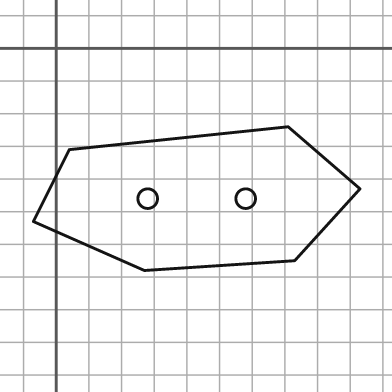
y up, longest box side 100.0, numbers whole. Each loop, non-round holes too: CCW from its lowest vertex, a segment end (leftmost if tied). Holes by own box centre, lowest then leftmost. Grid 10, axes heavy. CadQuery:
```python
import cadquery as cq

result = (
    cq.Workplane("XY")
    .moveTo(27.0, -68.0)
    .lineTo(73.0, -65.0)
    .lineTo(93.0, -43.0)
    .lineTo(71.0, -24.0)
    .lineTo(4.0, -31.0)
    .lineTo(-7.0, -53.0)
    .close()
    .moveTo(28.0, -46.0)
    .circle(3.0)
    .moveTo(58.0, -46.0)
    .circle(3.0)
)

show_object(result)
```